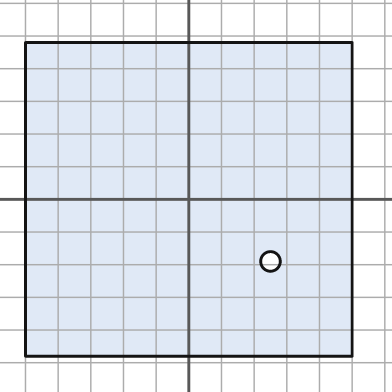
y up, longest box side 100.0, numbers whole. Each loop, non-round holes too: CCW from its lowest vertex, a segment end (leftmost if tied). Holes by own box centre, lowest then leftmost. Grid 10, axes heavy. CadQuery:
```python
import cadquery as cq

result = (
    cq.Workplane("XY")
    .moveTo(-50.0, -48.0)
    .lineTo(50.0, -48.0)
    .lineTo(50.0, 48.0)
    .lineTo(-50.0, 48.0)
    .close()
    .moveTo(25.0, -19.0)
    .circle(3.0)
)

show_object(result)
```